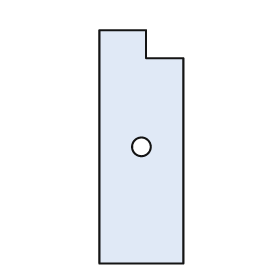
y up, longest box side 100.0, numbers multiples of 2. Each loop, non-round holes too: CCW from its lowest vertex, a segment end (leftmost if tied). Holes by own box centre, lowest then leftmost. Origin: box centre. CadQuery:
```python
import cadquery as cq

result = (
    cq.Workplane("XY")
    .moveTo(-18.0, -50.0)
    .lineTo(18.0, -50.0)
    .lineTo(18.0, 38.0)
    .lineTo(2.0, 38.0)
    .lineTo(2.0, 50.0)
    .lineTo(-18.0, 50.0)
    .close()
    .moveTo(0.0, 0.0)
    .circle(4.0)
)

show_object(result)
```